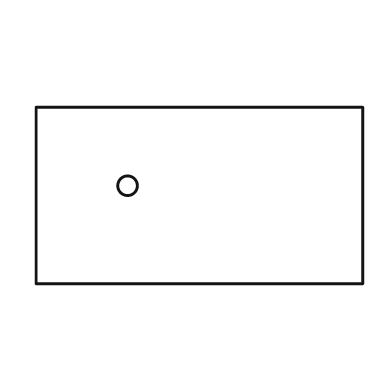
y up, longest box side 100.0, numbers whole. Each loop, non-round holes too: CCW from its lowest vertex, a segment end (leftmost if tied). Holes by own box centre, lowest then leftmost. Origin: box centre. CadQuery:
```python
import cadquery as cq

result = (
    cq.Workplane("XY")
    .moveTo(-50.0, -27.0)
    .lineTo(50.0, -27.0)
    .lineTo(50.0, 27.0)
    .lineTo(-50.0, 27.0)
    .close()
    .moveTo(-22.0, 3.0)
    .circle(3.0)
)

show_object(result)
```